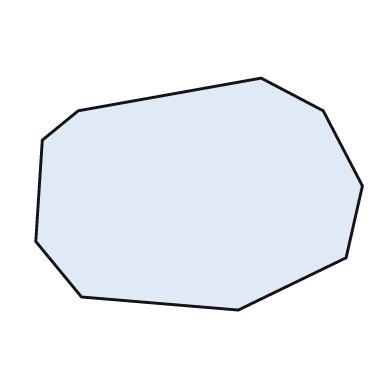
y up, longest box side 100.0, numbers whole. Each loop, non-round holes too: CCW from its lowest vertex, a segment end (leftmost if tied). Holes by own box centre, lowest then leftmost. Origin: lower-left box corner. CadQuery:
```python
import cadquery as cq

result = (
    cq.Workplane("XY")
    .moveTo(62.0, 0.0)
    .lineTo(95.0, 16.0)
    .lineTo(100.0, 38.0)
    .lineTo(88.0, 61.0)
    .lineTo(69.0, 71.0)
    .lineTo(13.0, 61.0)
    .lineTo(2.0, 52.0)
    .lineTo(0.0, 21.0)
    .lineTo(14.0, 4.0)
    .close()
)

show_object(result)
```